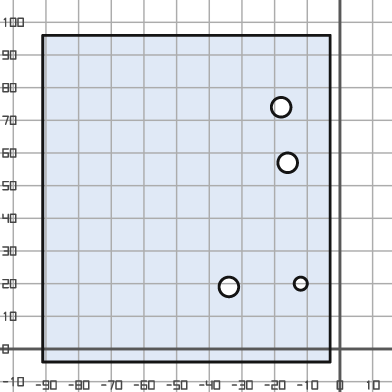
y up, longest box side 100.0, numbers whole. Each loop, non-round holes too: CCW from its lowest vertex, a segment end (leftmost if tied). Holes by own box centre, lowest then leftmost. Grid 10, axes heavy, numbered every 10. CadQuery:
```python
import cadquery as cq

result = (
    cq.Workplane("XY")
    .moveTo(-91.0, -4.0)
    .lineTo(-3.0, -4.0)
    .lineTo(-3.0, 96.0)
    .lineTo(-91.0, 96.0)
    .close()
    .moveTo(-34.0, 19.0)
    .circle(3.0)
    .moveTo(-12.0, 20.0)
    .circle(2.0)
    .moveTo(-16.0, 57.0)
    .circle(3.0)
    .moveTo(-18.0, 74.0)
    .circle(3.0)
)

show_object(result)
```